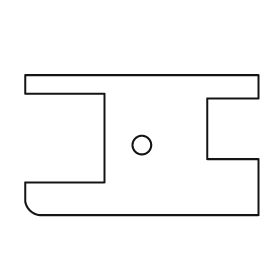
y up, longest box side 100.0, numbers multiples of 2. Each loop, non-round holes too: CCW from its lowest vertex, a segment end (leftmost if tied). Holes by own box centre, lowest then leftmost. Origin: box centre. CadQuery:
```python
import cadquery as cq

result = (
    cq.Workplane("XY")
    .moveTo(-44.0, -30.0)
    .lineTo(50.0, -30.0)
    .lineTo(50.0, -6.0)
    .lineTo(28.0, -6.0)
    .lineTo(28.0, 20.0)
    .lineTo(50.0, 20.0)
    .lineTo(50.0, 30.0)
    .lineTo(-50.0, 30.0)
    .lineTo(-50.0, 22.0)
    .lineTo(-16.0, 22.0)
    .lineTo(-16.0, -16.0)
    .lineTo(-50.0, -16.0)
    .lineTo(-50.0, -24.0)
    .threePointArc((-48.0, -28.0), (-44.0, -30.0))
    .close()
    .moveTo(0.0, 0.0)
    .circle(4.0)
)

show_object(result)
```